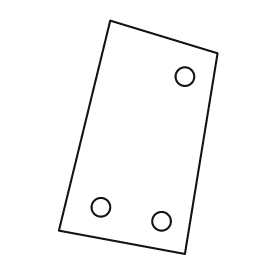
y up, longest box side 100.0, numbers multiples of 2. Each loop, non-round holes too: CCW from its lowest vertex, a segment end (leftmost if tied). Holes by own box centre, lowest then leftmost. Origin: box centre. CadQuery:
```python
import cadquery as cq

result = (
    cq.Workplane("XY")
    .moveTo(20.0, -50.0)
    .lineTo(34.0, 36.0)
    .lineTo(-12.0, 50.0)
    .lineTo(-34.0, -40.0)
    .close()
    .moveTo(10.0, -36.0)
    .circle(4.0)
    .moveTo(-16.0, -30.0)
    .circle(4.0)
    .moveTo(20.0, 26.0)
    .circle(4.0)
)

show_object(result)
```